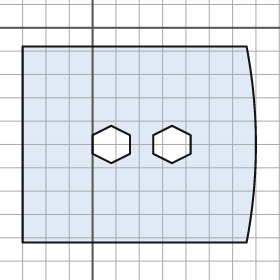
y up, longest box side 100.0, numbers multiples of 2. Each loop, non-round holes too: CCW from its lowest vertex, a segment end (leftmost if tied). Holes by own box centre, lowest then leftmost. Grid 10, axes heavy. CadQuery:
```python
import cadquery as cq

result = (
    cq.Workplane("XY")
    .moveTo(-30.0, -92.0)
    .lineTo(66.0, -92.0)
    .threePointArc((70.0, -50.0), (66.0, -8.0))
    .lineTo(-30.0, -8.0)
    .close()
    .moveTo(8.0, -58.0)
    .lineTo(16.0, -54.0)
    .lineTo(16.0, -46.0)
    .lineTo(8.0, -42.0)
    .lineTo(0.0, -46.0)
    .lineTo(0.0, -54.0)
    .close()
    .moveTo(34.0, -58.0)
    .lineTo(42.0, -54.0)
    .lineTo(42.0, -46.0)
    .lineTo(34.0, -42.0)
    .lineTo(26.0, -46.0)
    .lineTo(26.0, -54.0)
    .close()
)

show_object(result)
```